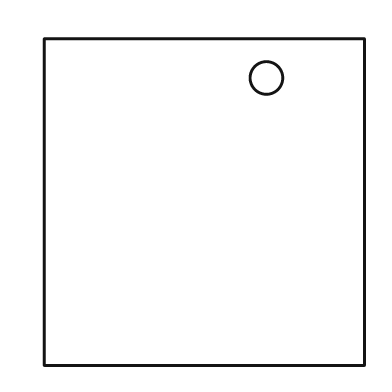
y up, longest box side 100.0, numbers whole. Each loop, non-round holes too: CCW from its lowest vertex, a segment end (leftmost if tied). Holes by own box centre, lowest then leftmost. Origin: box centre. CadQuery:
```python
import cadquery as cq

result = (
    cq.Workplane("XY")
    .moveTo(-49.0, -50.0)
    .lineTo(49.0, -50.0)
    .lineTo(49.0, 50.0)
    .lineTo(-49.0, 50.0)
    .close()
    .moveTo(19.0, 38.0)
    .circle(5.0)
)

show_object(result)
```